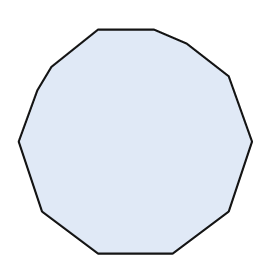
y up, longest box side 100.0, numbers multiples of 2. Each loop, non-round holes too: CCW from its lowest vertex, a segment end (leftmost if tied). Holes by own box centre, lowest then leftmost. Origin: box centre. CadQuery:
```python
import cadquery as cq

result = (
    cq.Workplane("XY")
    .moveTo(-16.0, -48.0)
    .lineTo(16.0, -48.0)
    .lineTo(40.0, -30.0)
    .lineTo(50.0, 0.0)
    .lineTo(40.0, 28.0)
    .lineTo(22.0, 42.0)
    .lineTo(8.0, 48.0)
    .lineTo(-16.0, 48.0)
    .lineTo(-36.0, 32.0)
    .lineTo(-42.0, 22.0)
    .lineTo(-50.0, 0.0)
    .lineTo(-40.0, -30.0)
    .close()
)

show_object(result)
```